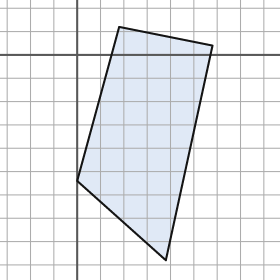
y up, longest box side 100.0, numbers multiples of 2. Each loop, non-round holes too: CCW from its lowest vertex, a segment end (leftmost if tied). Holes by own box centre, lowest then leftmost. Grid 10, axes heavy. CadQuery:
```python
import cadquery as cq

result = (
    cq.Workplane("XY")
    .moveTo(38.0, -88.0)
    .lineTo(58.0, 4.0)
    .lineTo(18.0, 12.0)
    .lineTo(0.0, -54.0)
    .close()
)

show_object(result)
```